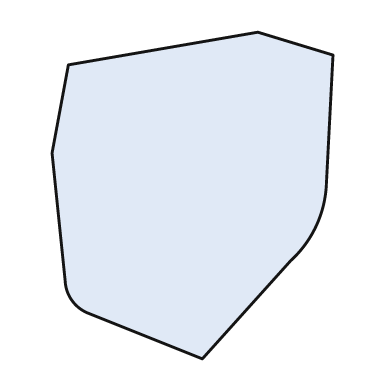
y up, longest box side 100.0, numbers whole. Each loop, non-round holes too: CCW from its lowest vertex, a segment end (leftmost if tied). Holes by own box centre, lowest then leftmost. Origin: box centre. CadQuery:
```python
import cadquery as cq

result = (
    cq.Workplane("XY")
    .moveTo(3.0, -50.0)
    .lineTo(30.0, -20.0)
    .threePointArc((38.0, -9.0), (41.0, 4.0))
    .lineTo(43.0, 43.0)
    .lineTo(20.0, 50.0)
    .lineTo(-38.0, 40.0)
    .lineTo(-43.0, 13.0)
    .lineTo(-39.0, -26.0)
    .threePointArc((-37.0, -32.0), (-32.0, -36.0))
    .close()
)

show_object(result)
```